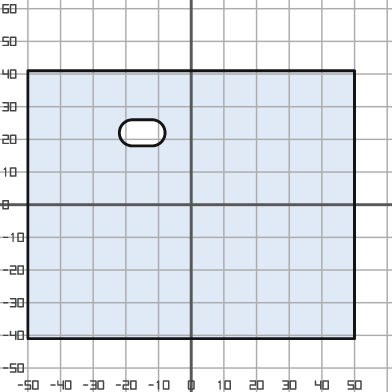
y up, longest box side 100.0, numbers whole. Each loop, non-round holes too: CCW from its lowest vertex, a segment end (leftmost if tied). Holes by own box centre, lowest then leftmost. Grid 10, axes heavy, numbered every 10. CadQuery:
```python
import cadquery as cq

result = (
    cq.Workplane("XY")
    .moveTo(-50.0, -41.0)
    .lineTo(50.0, -41.0)
    .lineTo(50.0, 41.0)
    .lineTo(-50.0, 41.0)
    .close()
    .moveTo(-18.0, 18.0)
    .lineTo(-12.0, 18.0)
    .threePointArc((-8.0, 22.0), (-12.0, 26.0))
    .lineTo(-18.0, 26.0)
    .threePointArc((-22.0, 22.0), (-18.0, 18.0))
    .close()
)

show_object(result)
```